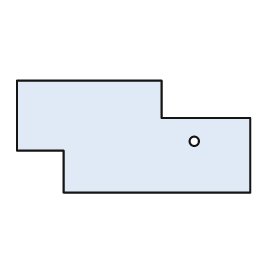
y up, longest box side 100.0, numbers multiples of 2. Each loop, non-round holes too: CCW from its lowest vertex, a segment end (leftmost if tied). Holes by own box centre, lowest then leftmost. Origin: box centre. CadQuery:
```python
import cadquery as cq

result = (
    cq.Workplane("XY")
    .moveTo(-30.0, -24.0)
    .lineTo(50.0, -24.0)
    .lineTo(50.0, 8.0)
    .lineTo(12.0, 8.0)
    .lineTo(12.0, 24.0)
    .lineTo(-50.0, 24.0)
    .lineTo(-50.0, -6.0)
    .lineTo(-30.0, -6.0)
    .close()
    .moveTo(26.0, -2.0)
    .circle(2.0)
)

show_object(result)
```